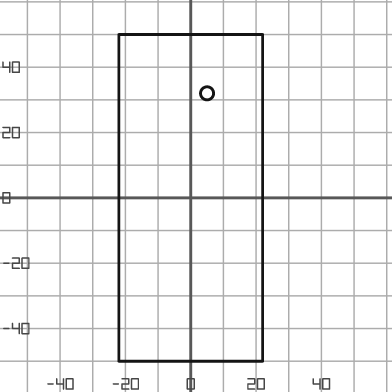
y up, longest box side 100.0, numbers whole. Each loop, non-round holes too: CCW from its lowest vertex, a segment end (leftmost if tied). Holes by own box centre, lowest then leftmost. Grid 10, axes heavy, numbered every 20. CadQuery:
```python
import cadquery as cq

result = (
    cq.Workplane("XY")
    .moveTo(-22.0, -50.0)
    .lineTo(22.0, -50.0)
    .lineTo(22.0, 50.0)
    .lineTo(-22.0, 50.0)
    .close()
    .moveTo(5.0, 32.0)
    .circle(2.0)
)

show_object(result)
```